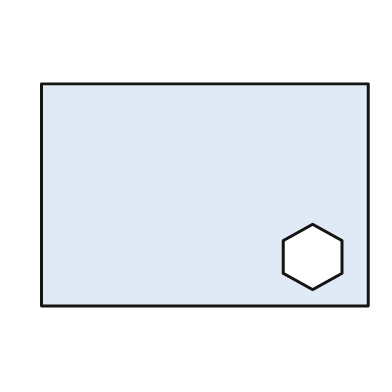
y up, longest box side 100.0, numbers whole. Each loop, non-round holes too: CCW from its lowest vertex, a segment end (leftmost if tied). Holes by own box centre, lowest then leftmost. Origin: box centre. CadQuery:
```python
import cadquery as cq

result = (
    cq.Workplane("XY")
    .moveTo(-50.0, -34.0)
    .lineTo(50.0, -34.0)
    .lineTo(50.0, 34.0)
    .lineTo(-50.0, 34.0)
    .close()
    .moveTo(33.0, -29.0)
    .lineTo(42.0, -24.0)
    .lineTo(42.0, -14.0)
    .lineTo(33.0, -9.0)
    .lineTo(24.0, -14.0)
    .lineTo(24.0, -24.0)
    .close()
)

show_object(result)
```